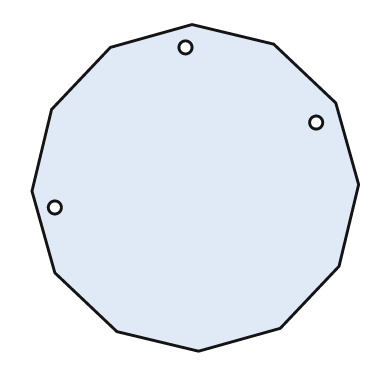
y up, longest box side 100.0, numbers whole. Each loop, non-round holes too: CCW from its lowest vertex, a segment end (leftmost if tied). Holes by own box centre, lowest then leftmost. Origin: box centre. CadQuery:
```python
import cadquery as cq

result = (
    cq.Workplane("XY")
    .moveTo(1.0, -50.0)
    .lineTo(26.0, -43.0)
    .lineTo(44.0, -24.0)
    .lineTo(50.0, 1.0)
    .lineTo(43.0, 26.0)
    .lineTo(24.0, 44.0)
    .lineTo(-1.0, 50.0)
    .lineTo(-26.0, 43.0)
    .lineTo(-44.0, 24.0)
    .lineTo(-50.0, -1.0)
    .lineTo(-43.0, -26.0)
    .lineTo(-24.0, -44.0)
    .close()
    .moveTo(-43.0, -6.0)
    .circle(2.0)
    .moveTo(37.0, 20.0)
    .circle(2.0)
    .moveTo(-3.0, 43.0)
    .circle(2.0)
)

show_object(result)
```